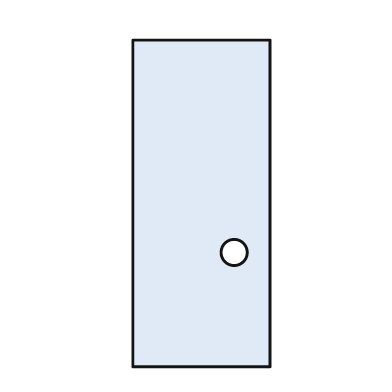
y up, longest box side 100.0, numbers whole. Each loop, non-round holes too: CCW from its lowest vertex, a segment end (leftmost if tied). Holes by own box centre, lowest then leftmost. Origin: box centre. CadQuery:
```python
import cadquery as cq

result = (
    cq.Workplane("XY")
    .moveTo(-21.0, -50.0)
    .lineTo(21.0, -50.0)
    .lineTo(21.0, 50.0)
    .lineTo(-21.0, 50.0)
    .close()
    .moveTo(10.0, -15.0)
    .circle(4.0)
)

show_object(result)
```